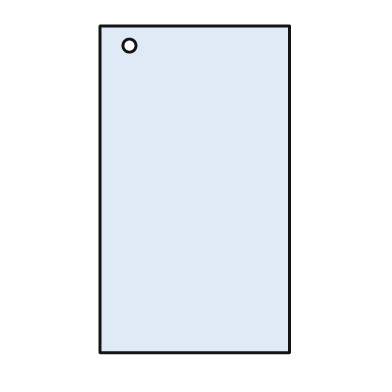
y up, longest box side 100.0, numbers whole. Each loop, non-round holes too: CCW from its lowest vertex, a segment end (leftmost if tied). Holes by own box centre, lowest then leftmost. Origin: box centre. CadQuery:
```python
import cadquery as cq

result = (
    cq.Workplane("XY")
    .moveTo(-29.0, -50.0)
    .lineTo(29.0, -50.0)
    .lineTo(29.0, 50.0)
    .lineTo(-29.0, 50.0)
    .close()
    .moveTo(-20.0, 44.0)
    .circle(2.0)
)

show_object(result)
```